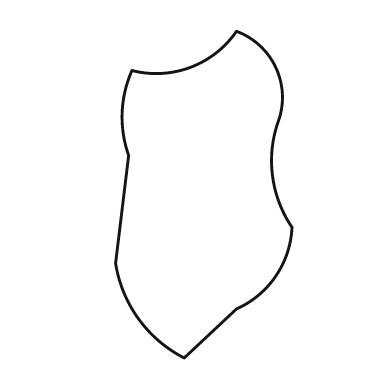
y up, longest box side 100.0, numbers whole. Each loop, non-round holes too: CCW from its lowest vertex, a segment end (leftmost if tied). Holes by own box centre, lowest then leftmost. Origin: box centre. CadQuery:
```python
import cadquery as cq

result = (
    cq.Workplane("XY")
    .moveTo(-6.0, -50.0)
    .lineTo(10.0, -35.0)
    .threePointArc((22.0, -25.0), (27.0, -10.0))
    .threePointArc((21.0, 6.0), (23.0, 23.0))
    .threePointArc((22.0, 39.0), (10.0, 50.0))
    .threePointArc((-4.0, 39.0), (-22.0, 38.0))
    .threePointArc((-25.0, 25.0), (-23.0, 12.0))
    .lineTo(-27.0, -21.0)
    .threePointArc((-20.0, -38.0), (-6.0, -50.0))
    .close()
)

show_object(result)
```